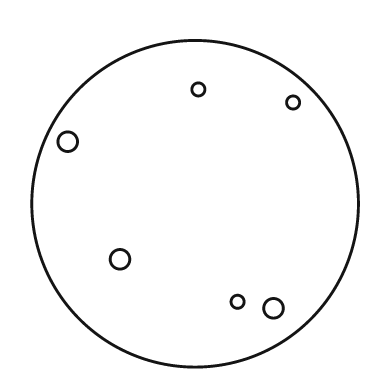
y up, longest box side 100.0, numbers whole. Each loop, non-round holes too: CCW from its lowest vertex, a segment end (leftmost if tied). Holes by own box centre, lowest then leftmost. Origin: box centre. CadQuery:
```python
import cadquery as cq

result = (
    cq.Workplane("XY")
    .moveTo(0.0, 0.0)
    .circle(50.0)
    .moveTo(24.0, -32.0)
    .circle(3.0)
    .moveTo(13.0, -30.0)
    .circle(2.0)
    .moveTo(-23.0, -17.0)
    .circle(3.0)
    .moveTo(-39.0, 19.0)
    .circle(3.0)
    .moveTo(30.0, 31.0)
    .circle(2.0)
    .moveTo(1.0, 35.0)
    .circle(2.0)
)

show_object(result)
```